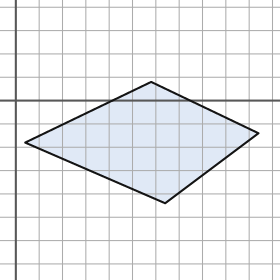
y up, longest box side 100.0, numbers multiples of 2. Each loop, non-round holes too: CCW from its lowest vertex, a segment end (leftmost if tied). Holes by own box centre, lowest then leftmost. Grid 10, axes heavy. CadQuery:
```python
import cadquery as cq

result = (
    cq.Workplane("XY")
    .moveTo(64.0, -44.0)
    .lineTo(104.0, -14.0)
    .lineTo(58.0, 8.0)
    .lineTo(4.0, -18.0)
    .close()
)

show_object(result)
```